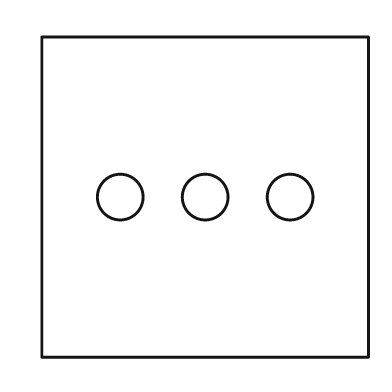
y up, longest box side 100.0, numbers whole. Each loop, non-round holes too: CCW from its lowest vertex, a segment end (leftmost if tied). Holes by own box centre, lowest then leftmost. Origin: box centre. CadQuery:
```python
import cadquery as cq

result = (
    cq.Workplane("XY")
    .moveTo(-50.0, -49.0)
    .lineTo(50.0, -49.0)
    .lineTo(50.0, 49.0)
    .lineTo(-50.0, 49.0)
    .close()
    .moveTo(-26.0, 0.0)
    .circle(7.0)
    .moveTo(0.0, 0.0)
    .circle(7.0)
    .moveTo(26.0, 0.0)
    .circle(7.0)
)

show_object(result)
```